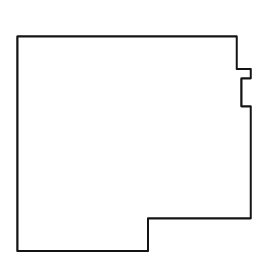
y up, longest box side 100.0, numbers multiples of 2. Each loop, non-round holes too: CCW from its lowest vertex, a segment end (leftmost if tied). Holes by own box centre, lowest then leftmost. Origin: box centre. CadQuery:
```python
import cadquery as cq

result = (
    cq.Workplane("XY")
    .moveTo(-50.0, -46.0)
    .lineTo(6.0, -46.0)
    .lineTo(6.0, -32.0)
    .lineTo(50.0, -32.0)
    .lineTo(50.0, 16.0)
    .lineTo(46.0, 16.0)
    .lineTo(46.0, 28.0)
    .lineTo(50.0, 28.0)
    .lineTo(50.0, 32.0)
    .lineTo(44.0, 32.0)
    .lineTo(44.0, 46.0)
    .lineTo(-50.0, 46.0)
    .close()
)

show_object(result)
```